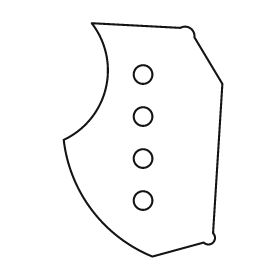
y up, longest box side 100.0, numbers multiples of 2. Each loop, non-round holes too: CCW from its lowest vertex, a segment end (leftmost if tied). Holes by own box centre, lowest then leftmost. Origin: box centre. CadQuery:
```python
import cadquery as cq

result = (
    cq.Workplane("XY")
    .moveTo(4.0, -50.0)
    .lineTo(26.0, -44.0)
    .threePointArc((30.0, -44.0), (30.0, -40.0))
    .lineTo(34.0, 24.0)
    .lineTo(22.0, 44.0)
    .threePointArc((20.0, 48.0), (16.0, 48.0))
    .lineTo(-22.0, 50.0)
    .threePointArc((-16.0, 22.0), (-34.0, 0.0))
    .threePointArc((-22.0, -30.0), (4.0, -50.0))
    .close()
    .moveTo(0.0, -26.0)
    .circle(4.0)
    .moveTo(0.0, -8.0)
    .circle(4.0)
    .moveTo(0.0, 10.0)
    .circle(4.0)
    .moveTo(0.0, 28.0)
    .circle(4.0)
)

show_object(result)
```